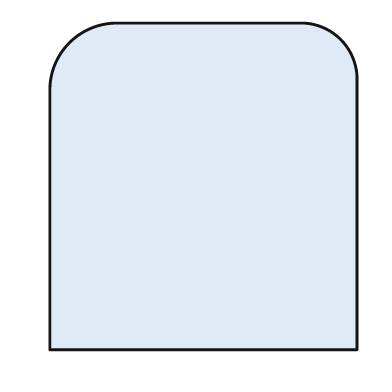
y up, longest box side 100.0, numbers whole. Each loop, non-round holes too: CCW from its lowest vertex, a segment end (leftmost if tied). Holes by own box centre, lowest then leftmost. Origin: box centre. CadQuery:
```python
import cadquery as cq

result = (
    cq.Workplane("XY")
    .moveTo(-47.0, -50.0)
    .lineTo(47.0, -50.0)
    .lineTo(47.0, 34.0)
    .threePointArc((42.0, 45.0), (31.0, 50.0))
    .lineTo(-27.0, 50.0)
    .threePointArc((-41.0, 44.0), (-47.0, 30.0))
    .close()
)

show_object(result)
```